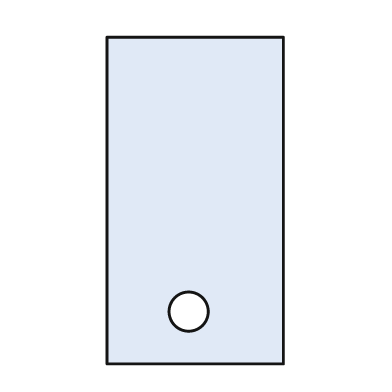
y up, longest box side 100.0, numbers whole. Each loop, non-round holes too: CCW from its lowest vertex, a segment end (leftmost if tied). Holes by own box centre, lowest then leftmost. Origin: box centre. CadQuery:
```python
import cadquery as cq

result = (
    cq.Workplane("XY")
    .moveTo(-27.0, -50.0)
    .lineTo(27.0, -50.0)
    .lineTo(27.0, 50.0)
    .lineTo(-27.0, 50.0)
    .close()
    .moveTo(-2.0, -34.0)
    .circle(6.0)
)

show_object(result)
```